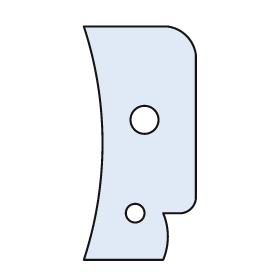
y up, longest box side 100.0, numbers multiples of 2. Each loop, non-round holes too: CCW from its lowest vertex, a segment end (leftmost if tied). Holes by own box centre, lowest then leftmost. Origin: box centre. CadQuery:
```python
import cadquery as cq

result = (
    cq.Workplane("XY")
    .moveTo(-24.0, -50.0)
    .lineTo(10.0, -50.0)
    .threePointArc((12.0, -40.0), (10.0, -30.0))
    .lineTo(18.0, -30.0)
    .threePointArc((22.0, -28.0), (24.0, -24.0))
    .lineTo(24.0, 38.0)
    .threePointArc((20.0, 46.0), (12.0, 50.0))
    .lineTo(-24.0, 50.0)
    .threePointArc((-16.0, 0.0), (-24.0, -50.0))
    .close()
    .moveTo(-2.0, -30.0)
    .circle(4.0)
    .moveTo(2.0, 10.0)
    .circle(6.0)
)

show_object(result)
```